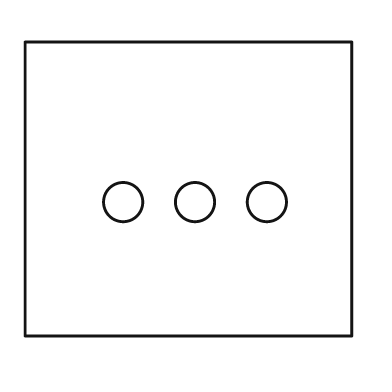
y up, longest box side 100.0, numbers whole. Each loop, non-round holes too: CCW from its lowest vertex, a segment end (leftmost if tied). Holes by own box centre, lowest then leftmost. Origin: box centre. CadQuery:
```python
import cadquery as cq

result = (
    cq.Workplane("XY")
    .moveTo(-50.0, -45.0)
    .lineTo(50.0, -45.0)
    .lineTo(50.0, 45.0)
    .lineTo(-50.0, 45.0)
    .close()
    .moveTo(-20.0, -4.0)
    .circle(6.0)
    .moveTo(2.0, -4.0)
    .circle(6.0)
    .moveTo(24.0, -4.0)
    .circle(6.0)
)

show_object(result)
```